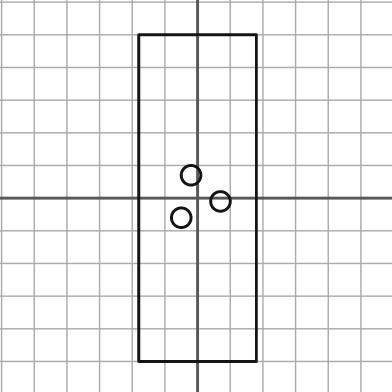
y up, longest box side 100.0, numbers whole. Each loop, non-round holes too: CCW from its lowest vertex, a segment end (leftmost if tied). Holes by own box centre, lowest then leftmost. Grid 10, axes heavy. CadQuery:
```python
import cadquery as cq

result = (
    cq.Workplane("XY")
    .moveTo(-18.0, -50.0)
    .lineTo(18.0, -50.0)
    .lineTo(18.0, 50.0)
    .lineTo(-18.0, 50.0)
    .close()
    .moveTo(-5.0, -6.0)
    .circle(3.0)
    .moveTo(7.0, -1.0)
    .circle(3.0)
    .moveTo(-2.0, 7.0)
    .circle(3.0)
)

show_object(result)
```